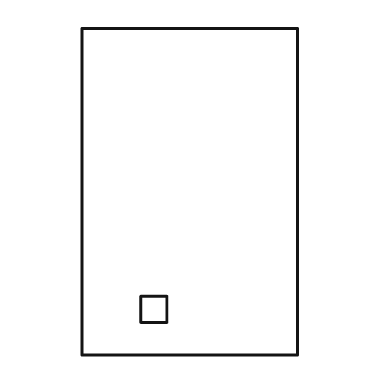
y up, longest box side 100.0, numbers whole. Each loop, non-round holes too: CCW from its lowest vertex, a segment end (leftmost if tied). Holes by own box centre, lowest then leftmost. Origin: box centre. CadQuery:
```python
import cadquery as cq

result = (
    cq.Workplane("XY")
    .moveTo(-33.0, -50.0)
    .lineTo(33.0, -50.0)
    .lineTo(33.0, 50.0)
    .lineTo(-33.0, 50.0)
    .close()
    .moveTo(-15.0, -40.0)
    .lineTo(-7.0, -40.0)
    .lineTo(-7.0, -32.0)
    .lineTo(-15.0, -32.0)
    .close()
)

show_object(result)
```